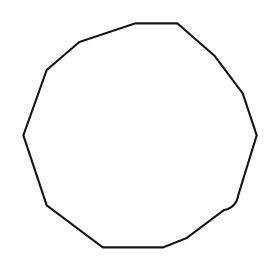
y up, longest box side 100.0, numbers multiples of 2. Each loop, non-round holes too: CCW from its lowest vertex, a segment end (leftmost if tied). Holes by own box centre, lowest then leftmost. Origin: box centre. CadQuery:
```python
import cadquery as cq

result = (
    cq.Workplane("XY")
    .moveTo(-16.0, -48.0)
    .lineTo(10.0, -48.0)
    .lineTo(20.0, -44.0)
    .lineTo(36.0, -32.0)
    .threePointArc((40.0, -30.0), (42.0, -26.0))
    .lineTo(50.0, 0.0)
    .lineTo(44.0, 18.0)
    .lineTo(32.0, 34.0)
    .lineTo(16.0, 48.0)
    .lineTo(-2.0, 48.0)
    .lineTo(-26.0, 40.0)
    .lineTo(-40.0, 28.0)
    .lineTo(-50.0, 0.0)
    .lineTo(-40.0, -30.0)
    .close()
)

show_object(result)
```